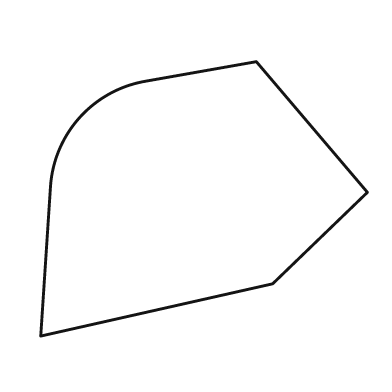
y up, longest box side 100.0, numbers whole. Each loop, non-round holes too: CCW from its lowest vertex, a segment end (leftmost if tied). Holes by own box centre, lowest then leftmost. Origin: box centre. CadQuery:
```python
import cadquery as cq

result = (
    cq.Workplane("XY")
    .moveTo(-50.0, -42.0)
    .lineTo(21.0, -26.0)
    .lineTo(50.0, 2.0)
    .lineTo(16.0, 42.0)
    .lineTo(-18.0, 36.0)
    .threePointArc((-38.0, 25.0), (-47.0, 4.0))
    .close()
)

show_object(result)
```